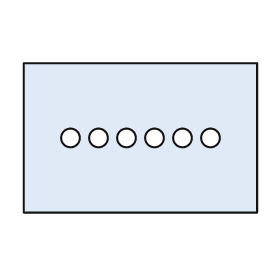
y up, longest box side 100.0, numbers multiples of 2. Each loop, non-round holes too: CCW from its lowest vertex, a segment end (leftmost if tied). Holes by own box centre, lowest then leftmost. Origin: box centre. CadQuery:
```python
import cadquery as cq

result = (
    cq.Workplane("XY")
    .moveTo(-50.0, -32.0)
    .lineTo(50.0, -32.0)
    .lineTo(50.0, 32.0)
    .lineTo(-50.0, 32.0)
    .close()
    .moveTo(-30.0, 0.0)
    .circle(4.0)
    .moveTo(-18.0, 0.0)
    .circle(4.0)
    .moveTo(-6.0, 0.0)
    .circle(4.0)
    .moveTo(6.0, 0.0)
    .circle(4.0)
    .moveTo(18.0, 0.0)
    .circle(4.0)
    .moveTo(30.0, 0.0)
    .circle(4.0)
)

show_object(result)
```